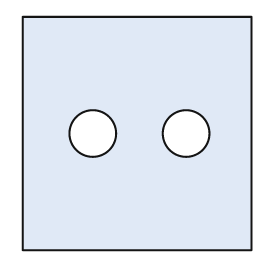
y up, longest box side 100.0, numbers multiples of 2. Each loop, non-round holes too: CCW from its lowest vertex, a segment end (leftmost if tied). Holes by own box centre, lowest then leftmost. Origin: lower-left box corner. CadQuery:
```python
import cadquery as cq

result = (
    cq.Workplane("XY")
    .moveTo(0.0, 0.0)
    .lineTo(98.0, 0.0)
    .lineTo(98.0, 100.0)
    .lineTo(0.0, 100.0)
    .close()
    .moveTo(30.0, 50.0)
    .circle(10.0)
    .moveTo(70.0, 50.0)
    .circle(10.0)
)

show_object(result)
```